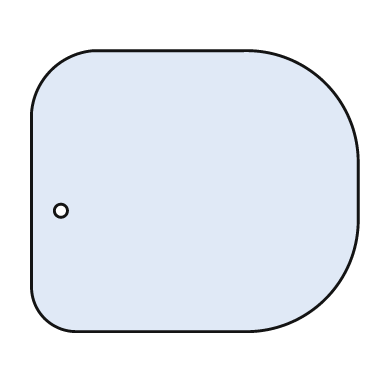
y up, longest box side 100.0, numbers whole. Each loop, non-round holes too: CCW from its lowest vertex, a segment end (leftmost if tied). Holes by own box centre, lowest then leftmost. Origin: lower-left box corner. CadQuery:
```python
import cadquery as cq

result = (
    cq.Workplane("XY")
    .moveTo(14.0, 0.0)
    .lineTo(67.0, 0.0)
    .threePointArc((90.0, 10.0), (100.0, 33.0))
    .lineTo(100.0, 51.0)
    .threePointArc((90.0, 76.0), (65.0, 86.0))
    .lineTo(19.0, 86.0)
    .threePointArc((6.0, 80.0), (0.0, 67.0))
    .lineTo(0.0, 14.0)
    .threePointArc((4.0, 4.0), (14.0, 0.0))
    .close()
    .moveTo(9.0, 37.0)
    .circle(2.0)
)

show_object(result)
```